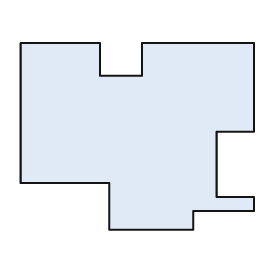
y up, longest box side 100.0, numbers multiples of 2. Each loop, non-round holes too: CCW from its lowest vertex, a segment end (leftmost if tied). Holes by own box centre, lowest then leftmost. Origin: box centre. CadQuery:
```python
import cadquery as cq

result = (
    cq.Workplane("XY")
    .moveTo(-12.0, -40.0)
    .lineTo(24.0, -40.0)
    .lineTo(24.0, -32.0)
    .lineTo(50.0, -32.0)
    .lineTo(50.0, -26.0)
    .lineTo(34.0, -26.0)
    .lineTo(34.0, 2.0)
    .lineTo(50.0, 2.0)
    .lineTo(50.0, 40.0)
    .lineTo(2.0, 40.0)
    .lineTo(2.0, 26.0)
    .lineTo(-16.0, 26.0)
    .lineTo(-16.0, 40.0)
    .lineTo(-50.0, 40.0)
    .lineTo(-50.0, -20.0)
    .lineTo(-12.0, -20.0)
    .close()
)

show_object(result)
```